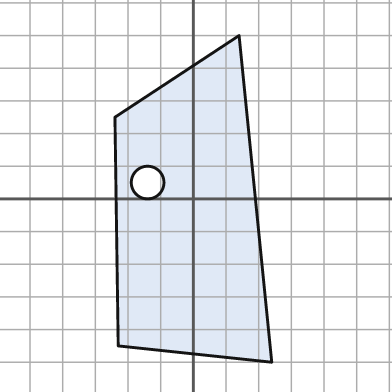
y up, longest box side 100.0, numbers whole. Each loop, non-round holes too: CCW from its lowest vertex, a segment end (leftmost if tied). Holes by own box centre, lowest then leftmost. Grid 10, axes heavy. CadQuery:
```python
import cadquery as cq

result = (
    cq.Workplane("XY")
    .moveTo(24.0, -50.0)
    .lineTo(14.0, 50.0)
    .lineTo(-24.0, 25.0)
    .lineTo(-23.0, -45.0)
    .close()
    .moveTo(-14.0, 5.0)
    .circle(5.0)
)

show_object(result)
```